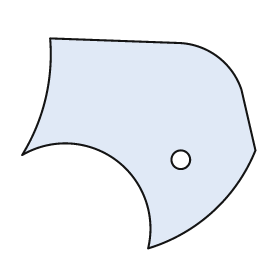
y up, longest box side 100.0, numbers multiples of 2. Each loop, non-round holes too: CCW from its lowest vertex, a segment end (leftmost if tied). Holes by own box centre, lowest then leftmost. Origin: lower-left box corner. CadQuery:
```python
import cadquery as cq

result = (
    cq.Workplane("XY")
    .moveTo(54.0, 0.0)
    .threePointArc((82.0, 16.0), (100.0, 42.0))
    .lineTo(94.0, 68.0)
    .threePointArc((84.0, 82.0), (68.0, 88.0))
    .lineTo(12.0, 90.0)
    .threePointArc((10.0, 64.0), (0.0, 40.0))
    .threePointArc((40.0, 38.0), (54.0, 0.0))
    .close()
    .moveTo(68.0, 38.0)
    .circle(4.0)
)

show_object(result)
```